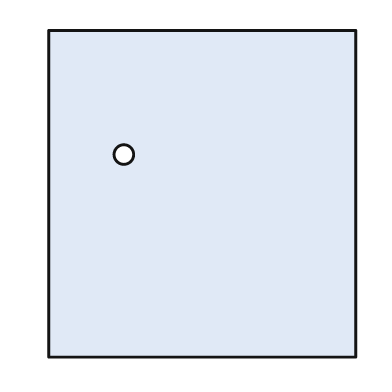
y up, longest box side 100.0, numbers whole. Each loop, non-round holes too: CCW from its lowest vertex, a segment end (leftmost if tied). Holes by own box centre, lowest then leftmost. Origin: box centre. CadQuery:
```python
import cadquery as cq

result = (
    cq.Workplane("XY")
    .moveTo(-47.0, -50.0)
    .lineTo(47.0, -50.0)
    .lineTo(47.0, 50.0)
    .lineTo(-47.0, 50.0)
    .close()
    .moveTo(-24.0, 12.0)
    .circle(3.0)
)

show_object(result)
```